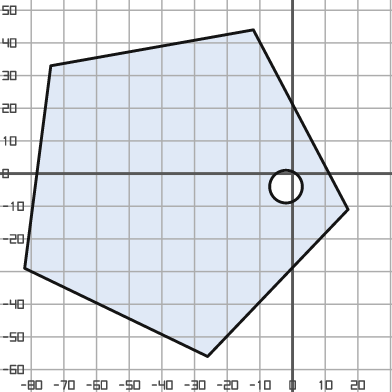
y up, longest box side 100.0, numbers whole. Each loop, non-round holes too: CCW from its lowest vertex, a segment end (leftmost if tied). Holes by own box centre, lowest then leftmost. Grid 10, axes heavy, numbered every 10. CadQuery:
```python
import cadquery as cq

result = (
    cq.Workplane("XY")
    .moveTo(-26.0, -56.0)
    .lineTo(17.0, -11.0)
    .lineTo(-12.0, 44.0)
    .lineTo(-74.0, 33.0)
    .lineTo(-82.0, -29.0)
    .close()
    .moveTo(-2.0, -4.0)
    .circle(5.0)
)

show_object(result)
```